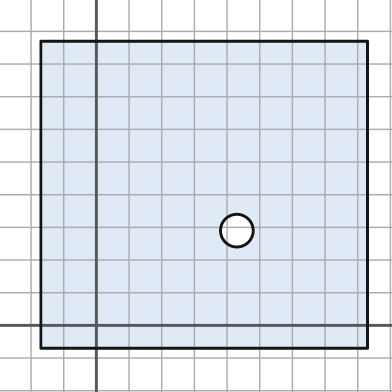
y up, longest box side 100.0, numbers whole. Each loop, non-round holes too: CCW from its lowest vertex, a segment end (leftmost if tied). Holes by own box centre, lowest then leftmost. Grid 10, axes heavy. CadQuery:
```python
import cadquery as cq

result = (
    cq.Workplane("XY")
    .moveTo(-17.0, -7.0)
    .lineTo(83.0, -7.0)
    .lineTo(83.0, 87.0)
    .lineTo(-17.0, 87.0)
    .close()
    .moveTo(43.0, 29.0)
    .circle(5.0)
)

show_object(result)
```